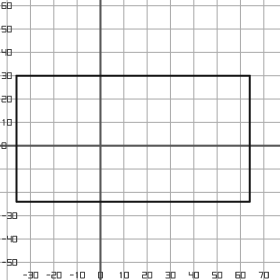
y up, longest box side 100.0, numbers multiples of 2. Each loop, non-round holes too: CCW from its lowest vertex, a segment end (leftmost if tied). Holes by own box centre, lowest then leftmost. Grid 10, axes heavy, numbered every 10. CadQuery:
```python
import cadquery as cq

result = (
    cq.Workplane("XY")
    .moveTo(-36.0, -24.0)
    .lineTo(64.0, -24.0)
    .lineTo(64.0, 30.0)
    .lineTo(-36.0, 30.0)
    .close()
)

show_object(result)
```